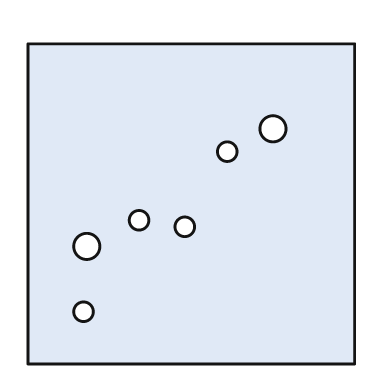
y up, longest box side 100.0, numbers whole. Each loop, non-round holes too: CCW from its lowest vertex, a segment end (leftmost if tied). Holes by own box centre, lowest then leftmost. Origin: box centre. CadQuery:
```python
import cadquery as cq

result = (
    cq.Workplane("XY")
    .moveTo(-50.0, -49.0)
    .lineTo(50.0, -49.0)
    .lineTo(50.0, 49.0)
    .lineTo(-50.0, 49.0)
    .close()
    .moveTo(-33.0, -33.0)
    .circle(3.0)
    .moveTo(-32.0, -13.0)
    .circle(4.0)
    .moveTo(-2.0, -7.0)
    .circle(3.0)
    .moveTo(-16.0, -5.0)
    .circle(3.0)
    .moveTo(11.0, 16.0)
    .circle(3.0)
    .moveTo(25.0, 23.0)
    .circle(4.0)
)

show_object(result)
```